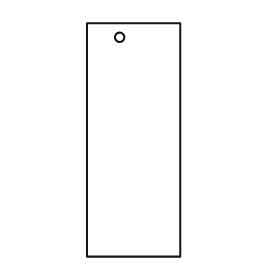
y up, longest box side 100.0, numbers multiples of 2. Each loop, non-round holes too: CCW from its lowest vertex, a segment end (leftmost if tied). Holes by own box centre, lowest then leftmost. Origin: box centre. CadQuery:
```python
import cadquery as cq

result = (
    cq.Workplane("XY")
    .moveTo(-20.0, -50.0)
    .lineTo(20.0, -50.0)
    .lineTo(20.0, 50.0)
    .lineTo(-20.0, 50.0)
    .close()
    .moveTo(-6.0, 44.0)
    .circle(2.0)
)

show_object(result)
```